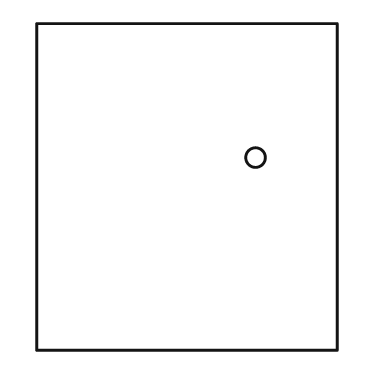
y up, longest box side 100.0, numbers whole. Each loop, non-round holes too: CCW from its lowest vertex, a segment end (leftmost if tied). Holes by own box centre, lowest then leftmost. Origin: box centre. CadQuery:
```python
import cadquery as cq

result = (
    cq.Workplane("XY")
    .moveTo(-46.0, -50.0)
    .lineTo(46.0, -50.0)
    .lineTo(46.0, 50.0)
    .lineTo(-46.0, 50.0)
    .close()
    .moveTo(21.0, 9.0)
    .circle(3.0)
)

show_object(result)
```